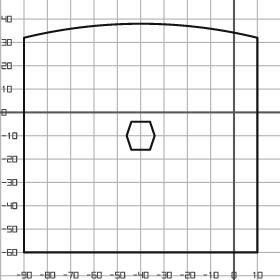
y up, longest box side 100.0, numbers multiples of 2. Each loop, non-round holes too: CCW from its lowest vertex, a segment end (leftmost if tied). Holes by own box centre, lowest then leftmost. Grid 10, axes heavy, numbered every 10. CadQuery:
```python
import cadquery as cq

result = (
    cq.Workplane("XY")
    .moveTo(-90.0, -60.0)
    .lineTo(10.0, -60.0)
    .lineTo(10.0, 32.0)
    .threePointArc((-40.0, 38.0), (-90.0, 32.0))
    .close()
    .moveTo(-44.0, -16.0)
    .lineTo(-36.0, -16.0)
    .lineTo(-34.0, -10.0)
    .lineTo(-36.0, -4.0)
    .lineTo(-44.0, -4.0)
    .lineTo(-46.0, -10.0)
    .close()
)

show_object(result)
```